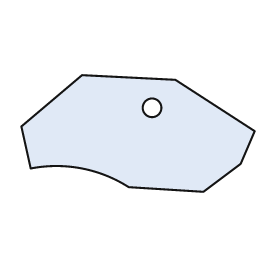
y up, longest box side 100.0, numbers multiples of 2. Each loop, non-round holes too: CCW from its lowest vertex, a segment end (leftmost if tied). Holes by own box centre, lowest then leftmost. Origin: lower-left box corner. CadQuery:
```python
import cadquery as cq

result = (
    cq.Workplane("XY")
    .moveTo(78.0, 0.0)
    .lineTo(94.0, 12.0)
    .lineTo(100.0, 26.0)
    .lineTo(66.0, 48.0)
    .lineTo(26.0, 50.0)
    .lineTo(0.0, 28.0)
    .lineTo(4.0, 10.0)
    .threePointArc((26.0, 10.0), (46.0, 2.0))
    .close()
    .moveTo(56.0, 36.0)
    .circle(4.0)
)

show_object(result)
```